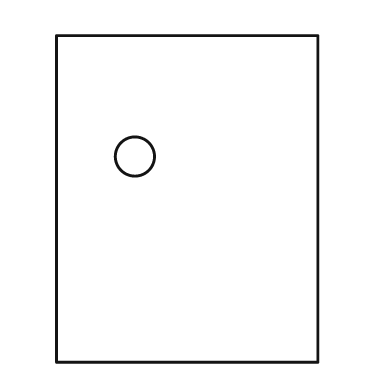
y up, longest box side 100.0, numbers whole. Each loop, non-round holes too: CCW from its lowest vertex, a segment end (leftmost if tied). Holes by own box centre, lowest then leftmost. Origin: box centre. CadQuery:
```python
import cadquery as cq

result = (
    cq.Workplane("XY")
    .moveTo(-40.0, -50.0)
    .lineTo(40.0, -50.0)
    .lineTo(40.0, 50.0)
    .lineTo(-40.0, 50.0)
    .close()
    .moveTo(-16.0, 13.0)
    .circle(6.0)
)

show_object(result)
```